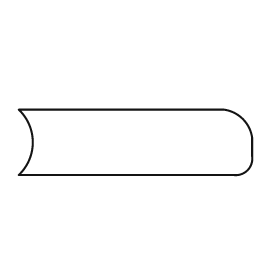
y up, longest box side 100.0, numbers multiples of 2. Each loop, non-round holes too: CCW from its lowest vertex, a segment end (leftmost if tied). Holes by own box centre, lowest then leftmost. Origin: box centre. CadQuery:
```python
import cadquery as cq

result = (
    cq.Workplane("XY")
    .moveTo(-50.0, -14.0)
    .lineTo(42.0, -14.0)
    .threePointArc((48.0, -12.0), (50.0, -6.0))
    .lineTo(50.0, 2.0)
    .threePointArc((46.0, 10.0), (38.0, 14.0))
    .lineTo(-50.0, 14.0)
    .threePointArc((-44.0, 0.0), (-50.0, -14.0))
    .close()
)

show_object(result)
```